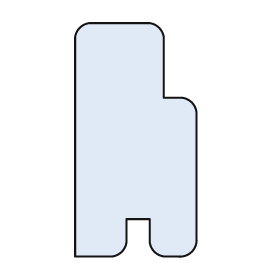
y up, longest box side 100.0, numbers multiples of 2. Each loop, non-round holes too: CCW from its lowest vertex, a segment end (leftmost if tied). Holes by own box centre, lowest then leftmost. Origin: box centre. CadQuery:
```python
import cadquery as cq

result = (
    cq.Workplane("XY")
    .moveTo(-26.0, -50.0)
    .lineTo(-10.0, -50.0)
    .threePointArc((-6.0, -48.0), (-4.0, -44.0))
    .lineTo(-4.0, -34.0)
    .lineTo(6.0, -34.0)
    .lineTo(6.0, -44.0)
    .threePointArc((8.0, -48.0), (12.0, -50.0))
    .lineTo(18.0, -50.0)
    .threePointArc((24.0, -48.0), (26.0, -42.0))
    .lineTo(26.0, 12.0)
    .threePointArc((24.0, 16.0), (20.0, 18.0))
    .lineTo(12.0, 18.0)
    .lineTo(12.0, 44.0)
    .threePointArc((10.0, 48.0), (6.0, 50.0))
    .lineTo(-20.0, 50.0)
    .threePointArc((-24.0, 48.0), (-26.0, 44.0))
    .close()
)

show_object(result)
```